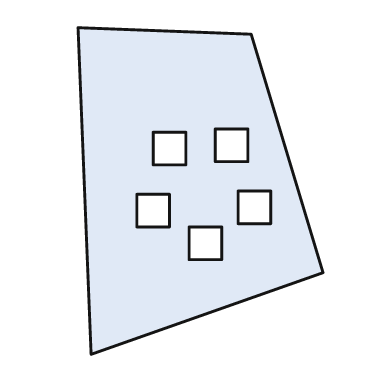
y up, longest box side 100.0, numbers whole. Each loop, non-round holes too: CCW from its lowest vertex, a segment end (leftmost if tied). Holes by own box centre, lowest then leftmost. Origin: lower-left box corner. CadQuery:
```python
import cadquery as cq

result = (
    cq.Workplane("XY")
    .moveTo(4.0, 0.0)
    .lineTo(75.0, 25.0)
    .lineTo(53.0, 98.0)
    .lineTo(0.0, 100.0)
    .close()
    .moveTo(34.0, 29.0)
    .lineTo(44.0, 29.0)
    .lineTo(44.0, 39.0)
    .lineTo(34.0, 39.0)
    .close()
    .moveTo(18.0, 39.0)
    .lineTo(28.0, 39.0)
    .lineTo(28.0, 49.0)
    .lineTo(18.0, 49.0)
    .close()
    .moveTo(49.0, 40.0)
    .lineTo(59.0, 40.0)
    .lineTo(59.0, 50.0)
    .lineTo(49.0, 50.0)
    .close()
    .moveTo(23.0, 58.0)
    .lineTo(33.0, 58.0)
    .lineTo(33.0, 68.0)
    .lineTo(23.0, 68.0)
    .close()
    .moveTo(42.0, 59.0)
    .lineTo(52.0, 59.0)
    .lineTo(52.0, 69.0)
    .lineTo(42.0, 69.0)
    .close()
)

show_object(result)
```